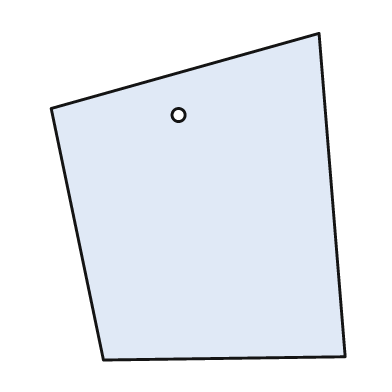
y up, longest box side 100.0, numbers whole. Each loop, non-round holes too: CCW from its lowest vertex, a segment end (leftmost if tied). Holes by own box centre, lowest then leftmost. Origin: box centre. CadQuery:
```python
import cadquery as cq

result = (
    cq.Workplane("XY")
    .moveTo(-29.0, -50.0)
    .lineTo(45.0, -49.0)
    .lineTo(37.0, 50.0)
    .lineTo(-45.0, 27.0)
    .close()
    .moveTo(-6.0, 25.0)
    .circle(2.0)
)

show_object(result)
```